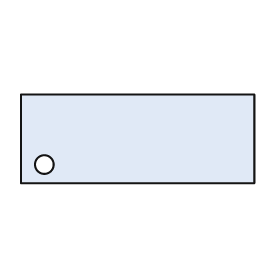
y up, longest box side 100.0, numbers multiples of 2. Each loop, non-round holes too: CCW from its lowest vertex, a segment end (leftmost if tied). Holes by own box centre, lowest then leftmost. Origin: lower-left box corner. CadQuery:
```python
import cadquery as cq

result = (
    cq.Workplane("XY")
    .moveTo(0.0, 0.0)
    .lineTo(100.0, 0.0)
    .lineTo(100.0, 38.0)
    .lineTo(0.0, 38.0)
    .close()
    .moveTo(10.0, 8.0)
    .circle(4.0)
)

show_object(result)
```